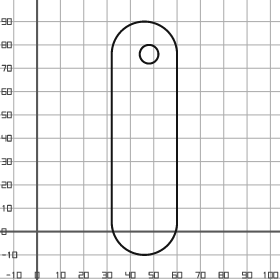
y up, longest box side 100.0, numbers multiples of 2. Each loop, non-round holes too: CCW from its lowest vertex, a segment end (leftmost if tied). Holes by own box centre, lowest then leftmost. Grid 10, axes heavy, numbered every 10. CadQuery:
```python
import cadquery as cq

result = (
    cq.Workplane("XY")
    .moveTo(32.0, 4.0)
    .threePointArc((46.0, -10.0), (60.0, 4.0))
    .lineTo(60.0, 76.0)
    .threePointArc((46.0, 90.0), (32.0, 76.0))
    .close()
    .moveTo(48.0, 76.0)
    .circle(4.0)
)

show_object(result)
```